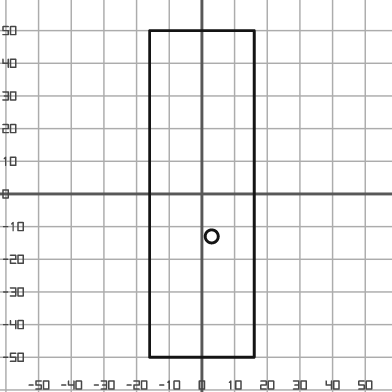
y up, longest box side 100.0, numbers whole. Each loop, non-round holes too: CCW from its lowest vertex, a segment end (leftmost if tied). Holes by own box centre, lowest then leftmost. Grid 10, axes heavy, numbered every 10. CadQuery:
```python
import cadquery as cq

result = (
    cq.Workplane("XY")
    .moveTo(-16.0, -50.0)
    .lineTo(16.0, -50.0)
    .lineTo(16.0, 50.0)
    .lineTo(-16.0, 50.0)
    .close()
    .moveTo(3.0, -13.0)
    .circle(2.0)
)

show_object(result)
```